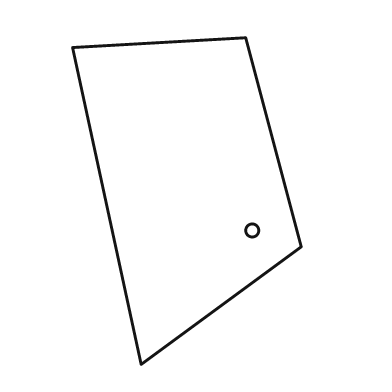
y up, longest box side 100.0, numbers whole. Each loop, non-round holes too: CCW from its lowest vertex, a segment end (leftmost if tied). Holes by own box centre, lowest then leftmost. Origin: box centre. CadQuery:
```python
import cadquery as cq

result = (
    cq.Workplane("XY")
    .moveTo(-14.0, -50.0)
    .lineTo(35.0, -14.0)
    .lineTo(18.0, 50.0)
    .lineTo(-35.0, 47.0)
    .close()
    .moveTo(20.0, -9.0)
    .circle(2.0)
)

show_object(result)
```